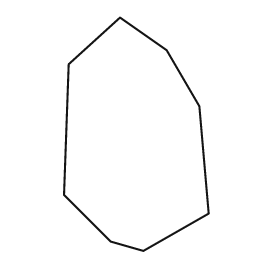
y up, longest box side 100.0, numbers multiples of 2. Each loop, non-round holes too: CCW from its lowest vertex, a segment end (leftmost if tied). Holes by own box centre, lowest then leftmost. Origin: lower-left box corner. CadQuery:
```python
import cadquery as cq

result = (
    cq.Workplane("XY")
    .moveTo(34.0, 0.0)
    .lineTo(62.0, 16.0)
    .lineTo(58.0, 62.0)
    .lineTo(44.0, 86.0)
    .lineTo(24.0, 100.0)
    .lineTo(2.0, 80.0)
    .lineTo(0.0, 24.0)
    .lineTo(20.0, 4.0)
    .close()
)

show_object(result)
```